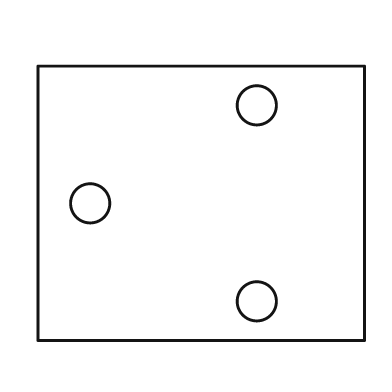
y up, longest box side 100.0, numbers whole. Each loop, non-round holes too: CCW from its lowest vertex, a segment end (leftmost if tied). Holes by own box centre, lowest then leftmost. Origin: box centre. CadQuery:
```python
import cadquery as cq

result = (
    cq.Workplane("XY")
    .moveTo(-50.0, -42.0)
    .lineTo(50.0, -42.0)
    .lineTo(50.0, 42.0)
    .lineTo(-50.0, 42.0)
    .close()
    .moveTo(17.0, -30.0)
    .circle(6.0)
    .moveTo(-34.0, 0.0)
    .circle(6.0)
    .moveTo(17.0, 30.0)
    .circle(6.0)
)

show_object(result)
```